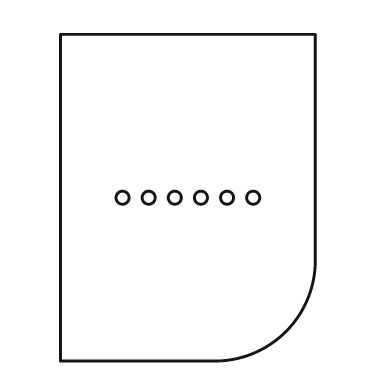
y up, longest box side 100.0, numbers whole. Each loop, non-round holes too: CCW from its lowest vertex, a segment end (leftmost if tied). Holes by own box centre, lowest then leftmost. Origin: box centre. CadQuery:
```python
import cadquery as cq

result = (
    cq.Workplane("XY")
    .moveTo(-39.0, -50.0)
    .lineTo(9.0, -50.0)
    .threePointArc((30.0, -41.0), (39.0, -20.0))
    .lineTo(39.0, 50.0)
    .lineTo(-39.0, 50.0)
    .close()
    .moveTo(-20.0, 0.0)
    .circle(2.0)
    .moveTo(-12.0, 0.0)
    .circle(2.0)
    .moveTo(-4.0, 0.0)
    .circle(2.0)
    .moveTo(4.0, 0.0)
    .circle(2.0)
    .moveTo(12.0, 0.0)
    .circle(2.0)
    .moveTo(20.0, 0.0)
    .circle(2.0)
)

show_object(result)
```